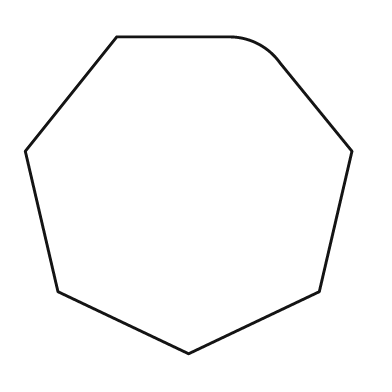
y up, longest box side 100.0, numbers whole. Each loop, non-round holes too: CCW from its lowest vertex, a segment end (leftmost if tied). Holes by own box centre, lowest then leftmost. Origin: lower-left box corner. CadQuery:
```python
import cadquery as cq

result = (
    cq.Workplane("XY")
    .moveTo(50.0, 0.0)
    .lineTo(90.0, 19.0)
    .lineTo(100.0, 62.0)
    .lineTo(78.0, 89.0)
    .threePointArc((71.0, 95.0), (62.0, 97.0))
    .lineTo(28.0, 97.0)
    .lineTo(0.0, 62.0)
    .lineTo(10.0, 19.0)
    .close()
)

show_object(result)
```